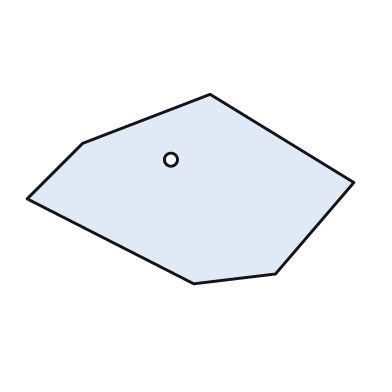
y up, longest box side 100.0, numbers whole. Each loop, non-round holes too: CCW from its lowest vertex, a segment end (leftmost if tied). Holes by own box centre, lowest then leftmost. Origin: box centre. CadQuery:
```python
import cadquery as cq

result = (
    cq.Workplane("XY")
    .moveTo(1.0, -29.0)
    .lineTo(26.0, -26.0)
    .lineTo(50.0, 2.0)
    .lineTo(6.0, 29.0)
    .lineTo(-33.0, 14.0)
    .lineTo(-50.0, -3.0)
    .close()
    .moveTo(-6.0, 9.0)
    .circle(2.0)
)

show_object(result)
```